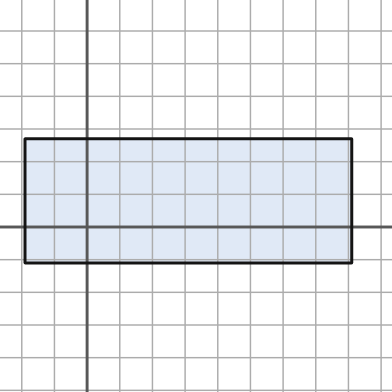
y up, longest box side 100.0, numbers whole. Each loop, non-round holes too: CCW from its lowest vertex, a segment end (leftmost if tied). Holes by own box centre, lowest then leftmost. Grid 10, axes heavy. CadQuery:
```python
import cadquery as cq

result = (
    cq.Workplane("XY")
    .moveTo(-19.0, -11.0)
    .lineTo(81.0, -11.0)
    .lineTo(81.0, 27.0)
    .lineTo(-19.0, 27.0)
    .close()
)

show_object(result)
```